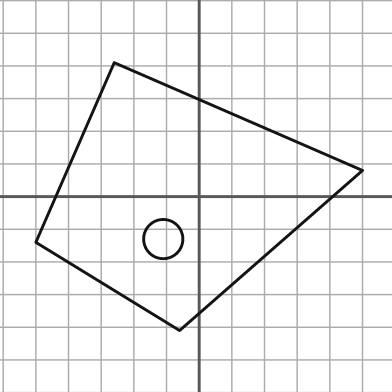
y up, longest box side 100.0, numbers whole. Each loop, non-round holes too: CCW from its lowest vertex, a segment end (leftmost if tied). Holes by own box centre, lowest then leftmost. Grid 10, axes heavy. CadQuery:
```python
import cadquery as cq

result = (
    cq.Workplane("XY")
    .moveTo(-6.0, -41.0)
    .lineTo(50.0, 8.0)
    .lineTo(-26.0, 41.0)
    .lineTo(-50.0, -14.0)
    .close()
    .moveTo(-11.0, -13.0)
    .circle(6.0)
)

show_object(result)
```